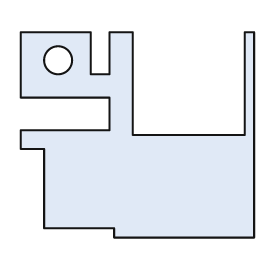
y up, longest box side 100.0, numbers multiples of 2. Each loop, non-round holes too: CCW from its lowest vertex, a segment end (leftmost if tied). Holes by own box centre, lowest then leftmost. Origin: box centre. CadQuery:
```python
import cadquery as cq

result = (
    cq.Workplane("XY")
    .moveTo(-10.0, -44.0)
    .lineTo(50.0, -44.0)
    .lineTo(50.0, 44.0)
    .lineTo(46.0, 44.0)
    .lineTo(46.0, 0.0)
    .lineTo(-2.0, 0.0)
    .lineTo(-2.0, 44.0)
    .lineTo(-12.0, 44.0)
    .lineTo(-12.0, 26.0)
    .lineTo(-20.0, 26.0)
    .lineTo(-20.0, 44.0)
    .lineTo(-50.0, 44.0)
    .lineTo(-50.0, 16.0)
    .lineTo(-12.0, 16.0)
    .lineTo(-12.0, 2.0)
    .lineTo(-50.0, 2.0)
    .lineTo(-50.0, -6.0)
    .lineTo(-40.0, -6.0)
    .lineTo(-40.0, -40.0)
    .lineTo(-10.0, -40.0)
    .close()
    .moveTo(-34.0, 32.0)
    .circle(6.0)
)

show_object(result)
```